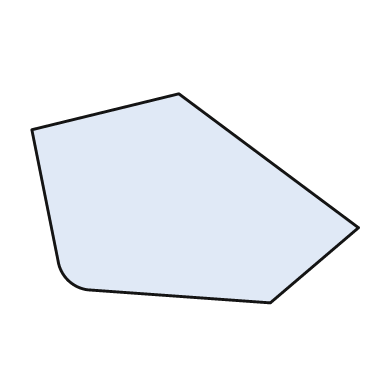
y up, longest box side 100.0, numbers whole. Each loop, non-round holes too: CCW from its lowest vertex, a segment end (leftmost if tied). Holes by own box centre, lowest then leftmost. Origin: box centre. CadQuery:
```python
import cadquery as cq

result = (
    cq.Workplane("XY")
    .moveTo(23.0, -32.0)
    .lineTo(50.0, -9.0)
    .lineTo(-5.0, 32.0)
    .lineTo(-50.0, 21.0)
    .lineTo(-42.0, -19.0)
    .threePointArc((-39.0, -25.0), (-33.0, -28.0))
    .close()
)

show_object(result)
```